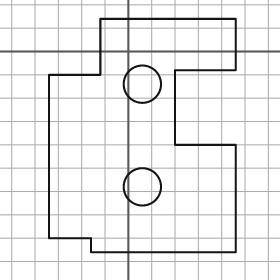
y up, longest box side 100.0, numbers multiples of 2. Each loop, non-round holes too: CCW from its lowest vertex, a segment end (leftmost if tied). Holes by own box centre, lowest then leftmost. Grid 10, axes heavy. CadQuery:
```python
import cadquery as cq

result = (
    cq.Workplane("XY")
    .moveTo(-16.0, -86.0)
    .lineTo(46.0, -86.0)
    .lineTo(46.0, -40.0)
    .lineTo(20.0, -40.0)
    .lineTo(20.0, -8.0)
    .lineTo(46.0, -8.0)
    .lineTo(46.0, 14.0)
    .lineTo(-12.0, 14.0)
    .lineTo(-12.0, -10.0)
    .lineTo(-34.0, -10.0)
    .lineTo(-34.0, -80.0)
    .lineTo(-16.0, -80.0)
    .close()
    .moveTo(6.0, -58.0)
    .circle(8.0)
    .moveTo(6.0, -14.0)
    .circle(8.0)
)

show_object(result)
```